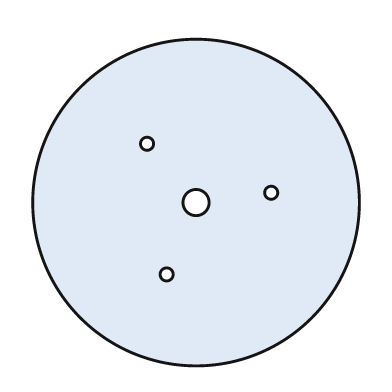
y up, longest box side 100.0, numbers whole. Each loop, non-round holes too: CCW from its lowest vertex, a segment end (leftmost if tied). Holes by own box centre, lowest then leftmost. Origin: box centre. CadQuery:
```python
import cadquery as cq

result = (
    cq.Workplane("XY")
    .moveTo(0.0, 0.0)
    .circle(50.0)
    .moveTo(-9.0, -22.0)
    .circle(2.0)
    .moveTo(0.0, 0.0)
    .circle(4.0)
    .moveTo(23.0, 3.0)
    .circle(2.0)
    .moveTo(-15.0, 18.0)
    .circle(2.0)
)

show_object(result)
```